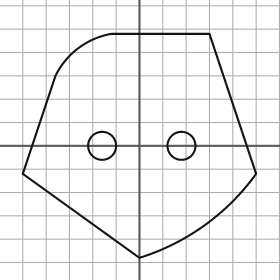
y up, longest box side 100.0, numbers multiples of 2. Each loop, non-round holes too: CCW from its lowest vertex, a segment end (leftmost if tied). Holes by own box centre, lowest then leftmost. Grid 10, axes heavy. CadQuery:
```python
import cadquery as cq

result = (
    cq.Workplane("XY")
    .moveTo(0.0, -48.0)
    .threePointArc((28.0, -34.0), (50.0, -12.0))
    .lineTo(30.0, 48.0)
    .lineTo(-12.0, 48.0)
    .threePointArc((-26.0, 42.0), (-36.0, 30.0))
    .lineTo(-50.0, -12.0)
    .close()
    .moveTo(-16.0, 0.0)
    .circle(6.0)
    .moveTo(18.0, 0.0)
    .circle(6.0)
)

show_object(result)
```